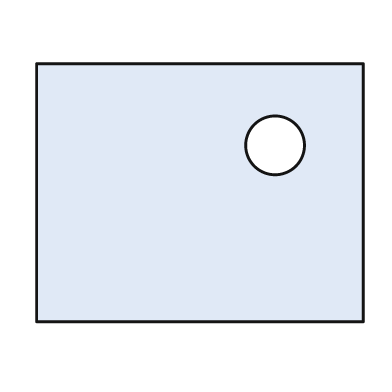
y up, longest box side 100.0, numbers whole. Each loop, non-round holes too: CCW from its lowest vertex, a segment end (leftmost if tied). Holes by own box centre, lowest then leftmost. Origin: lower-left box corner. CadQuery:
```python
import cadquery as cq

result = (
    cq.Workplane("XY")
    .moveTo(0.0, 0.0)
    .lineTo(100.0, 0.0)
    .lineTo(100.0, 79.0)
    .lineTo(0.0, 79.0)
    .close()
    .moveTo(73.0, 54.0)
    .circle(9.0)
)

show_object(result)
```